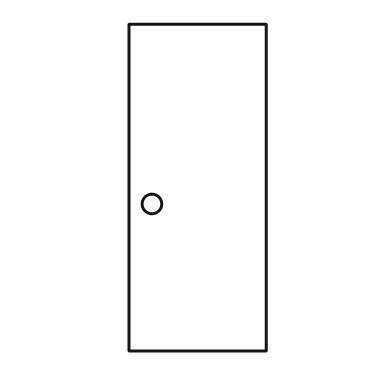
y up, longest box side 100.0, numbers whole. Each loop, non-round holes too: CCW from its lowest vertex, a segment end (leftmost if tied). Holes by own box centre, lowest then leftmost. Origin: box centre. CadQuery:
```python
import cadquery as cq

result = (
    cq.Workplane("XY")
    .moveTo(-21.0, -50.0)
    .lineTo(21.0, -50.0)
    .lineTo(21.0, 50.0)
    .lineTo(-21.0, 50.0)
    .close()
    .moveTo(-14.0, -5.0)
    .circle(3.0)
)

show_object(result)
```